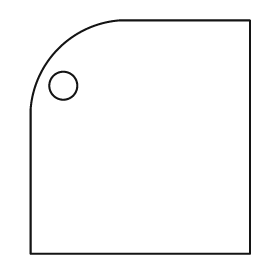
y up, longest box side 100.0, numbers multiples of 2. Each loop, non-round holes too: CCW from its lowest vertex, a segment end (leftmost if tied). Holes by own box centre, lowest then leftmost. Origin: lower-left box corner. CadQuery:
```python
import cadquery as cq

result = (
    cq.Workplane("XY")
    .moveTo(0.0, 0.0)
    .lineTo(94.0, 0.0)
    .lineTo(94.0, 100.0)
    .lineTo(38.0, 100.0)
    .threePointArc((12.0, 88.0), (0.0, 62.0))
    .close()
    .moveTo(14.0, 72.0)
    .circle(6.0)
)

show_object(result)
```